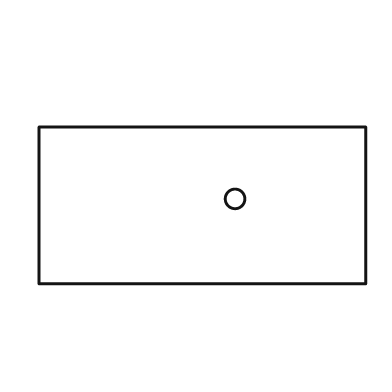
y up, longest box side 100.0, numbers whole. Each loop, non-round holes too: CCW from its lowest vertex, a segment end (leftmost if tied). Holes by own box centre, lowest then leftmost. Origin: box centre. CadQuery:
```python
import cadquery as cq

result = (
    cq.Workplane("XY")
    .moveTo(-50.0, -24.0)
    .lineTo(50.0, -24.0)
    .lineTo(50.0, 24.0)
    .lineTo(-50.0, 24.0)
    .close()
    .moveTo(10.0, 2.0)
    .circle(3.0)
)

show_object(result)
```